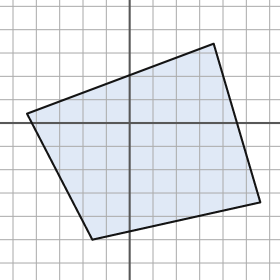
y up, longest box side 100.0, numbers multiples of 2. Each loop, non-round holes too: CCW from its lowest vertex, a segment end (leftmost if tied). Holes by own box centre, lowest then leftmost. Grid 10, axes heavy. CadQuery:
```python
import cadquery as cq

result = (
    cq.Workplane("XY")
    .moveTo(-16.0, -50.0)
    .lineTo(56.0, -34.0)
    .lineTo(36.0, 34.0)
    .lineTo(-44.0, 4.0)
    .close()
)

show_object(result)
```